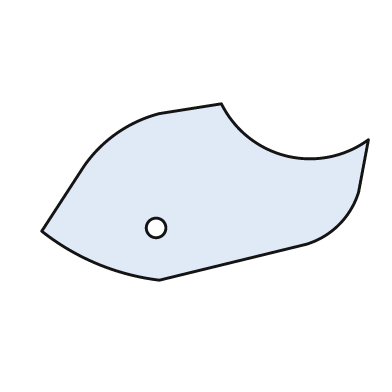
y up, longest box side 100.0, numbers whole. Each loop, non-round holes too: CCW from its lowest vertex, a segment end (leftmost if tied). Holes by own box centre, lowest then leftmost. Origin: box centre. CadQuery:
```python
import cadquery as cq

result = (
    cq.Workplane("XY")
    .moveTo(-14.0, -27.0)
    .lineTo(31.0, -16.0)
    .threePointArc((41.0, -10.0), (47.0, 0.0))
    .lineTo(50.0, 16.0)
    .threePointArc((25.0, 11.0), (5.0, 27.0))
    .lineTo(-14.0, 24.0)
    .threePointArc((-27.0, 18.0), (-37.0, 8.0))
    .lineTo(-50.0, -12.0)
    .threePointArc((-33.0, -22.0), (-14.0, -27.0))
    .close()
    .moveTo(-15.0, -11.0)
    .circle(3.0)
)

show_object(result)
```